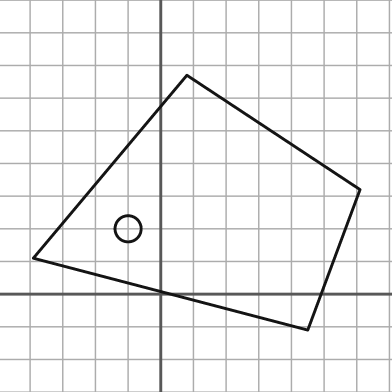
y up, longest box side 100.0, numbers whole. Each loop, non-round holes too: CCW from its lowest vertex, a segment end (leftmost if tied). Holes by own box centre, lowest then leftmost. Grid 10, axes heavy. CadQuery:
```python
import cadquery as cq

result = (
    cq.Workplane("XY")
    .moveTo(45.0, -11.0)
    .lineTo(61.0, 32.0)
    .lineTo(8.0, 67.0)
    .lineTo(-39.0, 11.0)
    .close()
    .moveTo(-10.0, 20.0)
    .circle(4.0)
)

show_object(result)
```